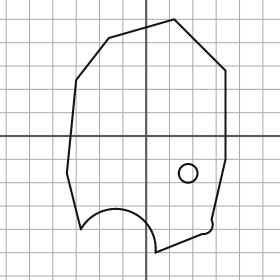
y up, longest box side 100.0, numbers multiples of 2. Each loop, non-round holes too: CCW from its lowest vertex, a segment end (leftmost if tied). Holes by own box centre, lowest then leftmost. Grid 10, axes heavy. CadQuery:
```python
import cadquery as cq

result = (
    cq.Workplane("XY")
    .moveTo(4.0, -50.0)
    .lineTo(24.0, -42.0)
    .threePointArc((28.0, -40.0), (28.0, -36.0))
    .lineTo(34.0, -10.0)
    .lineTo(34.0, 28.0)
    .lineTo(12.0, 50.0)
    .lineTo(-16.0, 42.0)
    .lineTo(-30.0, 24.0)
    .lineTo(-34.0, -16.0)
    .lineTo(-28.0, -40.0)
    .threePointArc((-8.0, -32.0), (4.0, -50.0))
    .close()
    .moveTo(18.0, -16.0)
    .circle(4.0)
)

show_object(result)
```